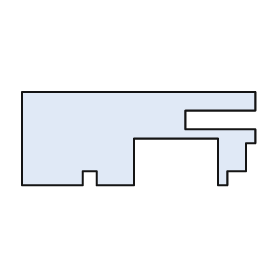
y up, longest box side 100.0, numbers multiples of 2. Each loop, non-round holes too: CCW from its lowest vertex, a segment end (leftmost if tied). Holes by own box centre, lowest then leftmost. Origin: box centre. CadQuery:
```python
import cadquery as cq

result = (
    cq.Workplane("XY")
    .moveTo(-50.0, -20.0)
    .lineTo(-24.0, -20.0)
    .lineTo(-24.0, -14.0)
    .lineTo(-18.0, -14.0)
    .lineTo(-18.0, -20.0)
    .lineTo(-2.0, -20.0)
    .lineTo(-2.0, 0.0)
    .lineTo(34.0, 0.0)
    .lineTo(34.0, -20.0)
    .lineTo(38.0, -20.0)
    .lineTo(38.0, -14.0)
    .lineTo(46.0, -14.0)
    .lineTo(46.0, -2.0)
    .lineTo(50.0, -2.0)
    .lineTo(50.0, 4.0)
    .lineTo(20.0, 4.0)
    .lineTo(20.0, 12.0)
    .lineTo(50.0, 12.0)
    .lineTo(50.0, 20.0)
    .lineTo(-50.0, 20.0)
    .close()
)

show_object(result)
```